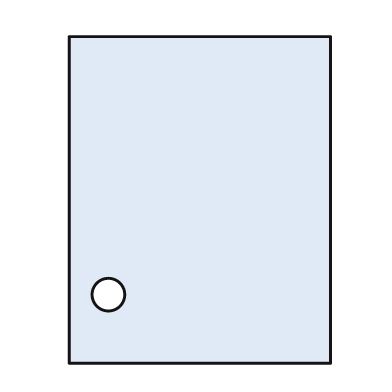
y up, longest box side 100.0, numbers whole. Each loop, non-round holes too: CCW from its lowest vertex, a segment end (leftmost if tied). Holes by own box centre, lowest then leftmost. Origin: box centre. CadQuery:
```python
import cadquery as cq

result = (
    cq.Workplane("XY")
    .moveTo(-40.0, -50.0)
    .lineTo(40.0, -50.0)
    .lineTo(40.0, 50.0)
    .lineTo(-40.0, 50.0)
    .close()
    .moveTo(-28.0, -29.0)
    .circle(5.0)
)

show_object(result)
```